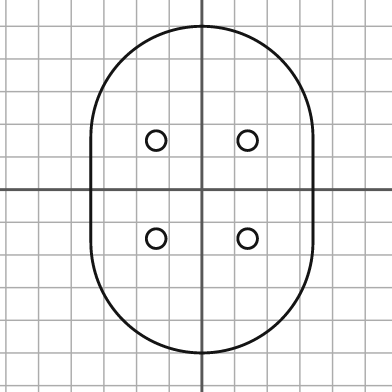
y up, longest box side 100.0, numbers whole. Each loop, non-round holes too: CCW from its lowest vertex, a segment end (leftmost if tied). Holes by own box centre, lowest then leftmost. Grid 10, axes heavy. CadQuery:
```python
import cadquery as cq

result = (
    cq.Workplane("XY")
    .moveTo(-34.0, -16.0)
    .threePointArc((0.0, -50.0), (34.0, -16.0))
    .lineTo(34.0, 16.0)
    .threePointArc((0.0, 50.0), (-34.0, 16.0))
    .close()
    .moveTo(-14.0, -15.0)
    .circle(3.0)
    .moveTo(14.0, -15.0)
    .circle(3.0)
    .moveTo(-14.0, 15.0)
    .circle(3.0)
    .moveTo(14.0, 15.0)
    .circle(3.0)
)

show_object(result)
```